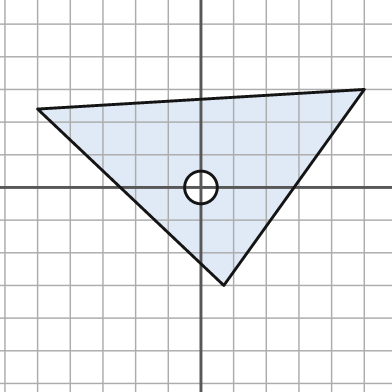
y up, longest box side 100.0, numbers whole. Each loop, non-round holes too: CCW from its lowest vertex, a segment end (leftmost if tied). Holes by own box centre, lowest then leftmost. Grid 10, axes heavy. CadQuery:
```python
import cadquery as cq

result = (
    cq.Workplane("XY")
    .moveTo(7.0, -30.0)
    .lineTo(50.0, 30.0)
    .lineTo(-50.0, 24.0)
    .close()
    .moveTo(0.0, 0.0)
    .circle(5.0)
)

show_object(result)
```